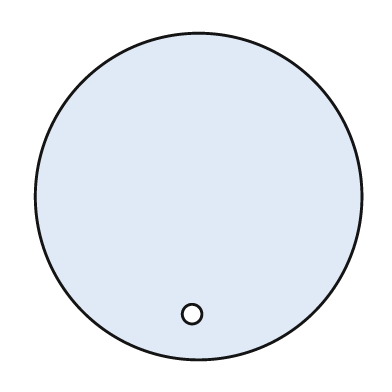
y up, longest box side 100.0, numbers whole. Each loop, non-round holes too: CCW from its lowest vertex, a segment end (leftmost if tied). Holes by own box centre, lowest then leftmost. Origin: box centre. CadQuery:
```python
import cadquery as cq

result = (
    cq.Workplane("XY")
    .moveTo(0.0, 0.0)
    .circle(50.0)
    .moveTo(-2.0, -36.0)
    .circle(3.0)
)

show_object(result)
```